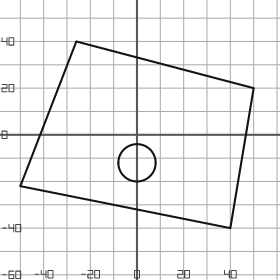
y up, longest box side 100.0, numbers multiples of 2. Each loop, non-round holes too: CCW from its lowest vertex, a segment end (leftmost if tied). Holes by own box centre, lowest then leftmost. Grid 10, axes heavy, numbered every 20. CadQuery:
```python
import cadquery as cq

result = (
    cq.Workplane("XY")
    .moveTo(40.0, -40.0)
    .lineTo(50.0, 20.0)
    .lineTo(-26.0, 40.0)
    .lineTo(-50.0, -22.0)
    .close()
    .moveTo(0.0, -12.0)
    .circle(8.0)
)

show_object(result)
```